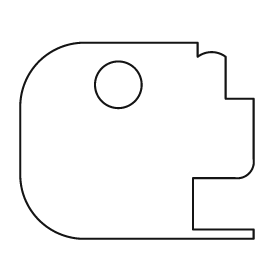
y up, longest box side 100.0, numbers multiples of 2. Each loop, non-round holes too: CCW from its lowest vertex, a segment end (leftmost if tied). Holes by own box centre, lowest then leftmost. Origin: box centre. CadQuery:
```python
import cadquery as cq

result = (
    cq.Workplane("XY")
    .moveTo(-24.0, -42.0)
    .lineTo(50.0, -42.0)
    .lineTo(50.0, -38.0)
    .lineTo(24.0, -38.0)
    .lineTo(24.0, -16.0)
    .lineTo(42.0, -16.0)
    .threePointArc((48.0, -14.0), (50.0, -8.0))
    .lineTo(50.0, 18.0)
    .lineTo(38.0, 18.0)
    .lineTo(38.0, 36.0)
    .threePointArc((32.0, 38.0), (26.0, 36.0))
    .lineTo(26.0, 42.0)
    .lineTo(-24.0, 42.0)
    .threePointArc((-42.0, 34.0), (-50.0, 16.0))
    .lineTo(-50.0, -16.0)
    .threePointArc((-42.0, -34.0), (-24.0, -42.0))
    .close()
    .moveTo(-8.0, 24.0)
    .circle(10.0)
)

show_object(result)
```